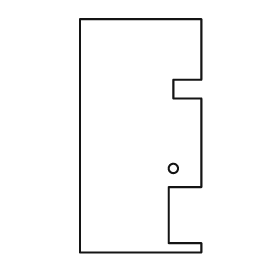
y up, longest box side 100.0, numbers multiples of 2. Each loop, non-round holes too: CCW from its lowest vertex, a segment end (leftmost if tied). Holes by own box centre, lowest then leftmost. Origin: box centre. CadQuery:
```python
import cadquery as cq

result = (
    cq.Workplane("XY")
    .moveTo(-26.0, -50.0)
    .lineTo(26.0, -50.0)
    .lineTo(26.0, -46.0)
    .lineTo(12.0, -46.0)
    .lineTo(12.0, -22.0)
    .lineTo(26.0, -22.0)
    .lineTo(26.0, 16.0)
    .lineTo(14.0, 16.0)
    .lineTo(14.0, 24.0)
    .lineTo(26.0, 24.0)
    .lineTo(26.0, 50.0)
    .lineTo(-26.0, 50.0)
    .close()
    .moveTo(14.0, -14.0)
    .circle(2.0)
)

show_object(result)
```